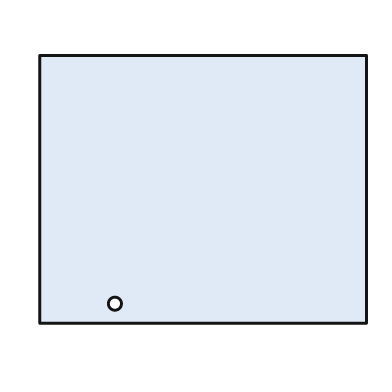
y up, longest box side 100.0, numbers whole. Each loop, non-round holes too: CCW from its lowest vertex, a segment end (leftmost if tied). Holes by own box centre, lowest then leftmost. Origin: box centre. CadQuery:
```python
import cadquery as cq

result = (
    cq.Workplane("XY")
    .moveTo(-50.0, -41.0)
    .lineTo(50.0, -41.0)
    .lineTo(50.0, 41.0)
    .lineTo(-50.0, 41.0)
    .close()
    .moveTo(-27.0, -35.0)
    .circle(2.0)
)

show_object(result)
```